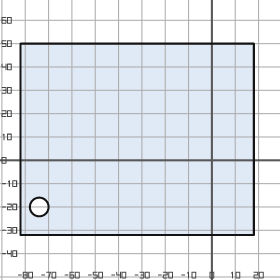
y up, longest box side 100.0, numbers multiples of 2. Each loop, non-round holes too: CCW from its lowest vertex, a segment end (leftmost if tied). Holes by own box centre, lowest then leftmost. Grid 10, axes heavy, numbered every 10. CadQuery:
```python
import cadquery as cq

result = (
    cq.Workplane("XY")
    .moveTo(-82.0, -32.0)
    .lineTo(18.0, -32.0)
    .lineTo(18.0, 50.0)
    .lineTo(-82.0, 50.0)
    .close()
    .moveTo(-74.0, -20.0)
    .circle(4.0)
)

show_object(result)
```